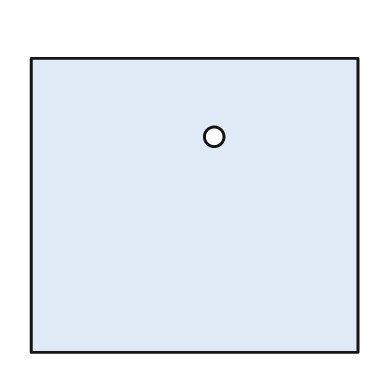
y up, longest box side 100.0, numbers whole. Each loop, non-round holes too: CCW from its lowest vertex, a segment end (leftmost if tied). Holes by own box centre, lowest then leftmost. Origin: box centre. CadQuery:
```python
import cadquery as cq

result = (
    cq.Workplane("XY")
    .moveTo(-50.0, -45.0)
    .lineTo(50.0, -45.0)
    .lineTo(50.0, 45.0)
    .lineTo(-50.0, 45.0)
    .close()
    .moveTo(6.0, 21.0)
    .circle(3.0)
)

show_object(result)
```